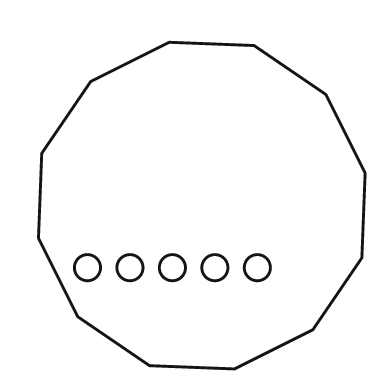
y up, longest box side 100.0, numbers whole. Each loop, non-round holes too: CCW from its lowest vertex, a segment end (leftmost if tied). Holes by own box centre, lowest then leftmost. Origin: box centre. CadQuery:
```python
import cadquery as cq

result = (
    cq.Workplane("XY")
    .moveTo(10.0, -50.0)
    .lineTo(34.0, -38.0)
    .lineTo(49.0, -16.0)
    .lineTo(50.0, 10.0)
    .lineTo(38.0, 34.0)
    .lineTo(16.0, 49.0)
    .lineTo(-10.0, 50.0)
    .lineTo(-34.0, 38.0)
    .lineTo(-49.0, 16.0)
    .lineTo(-50.0, -10.0)
    .lineTo(-38.0, -34.0)
    .lineTo(-16.0, -49.0)
    .close()
    .moveTo(-35.0, -19.0)
    .circle(4.0)
    .moveTo(-22.0, -19.0)
    .circle(4.0)
    .moveTo(-9.0, -19.0)
    .circle(4.0)
    .moveTo(4.0, -19.0)
    .circle(4.0)
    .moveTo(17.0, -19.0)
    .circle(4.0)
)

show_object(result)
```